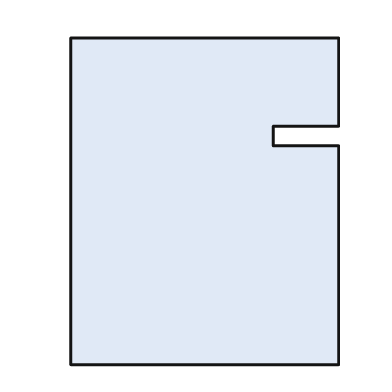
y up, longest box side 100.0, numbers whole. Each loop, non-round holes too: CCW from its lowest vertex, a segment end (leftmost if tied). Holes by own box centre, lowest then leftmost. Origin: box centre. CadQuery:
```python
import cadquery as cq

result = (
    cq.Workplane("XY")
    .moveTo(-41.0, -50.0)
    .lineTo(41.0, -50.0)
    .lineTo(41.0, 17.0)
    .lineTo(21.0, 17.0)
    .lineTo(21.0, 23.0)
    .lineTo(41.0, 23.0)
    .lineTo(41.0, 50.0)
    .lineTo(-41.0, 50.0)
    .close()
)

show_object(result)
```